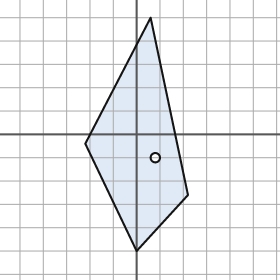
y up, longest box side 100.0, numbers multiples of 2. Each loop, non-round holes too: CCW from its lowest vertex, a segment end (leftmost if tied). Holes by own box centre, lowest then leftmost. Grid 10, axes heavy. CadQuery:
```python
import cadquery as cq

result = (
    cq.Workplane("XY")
    .moveTo(0.0, -50.0)
    .lineTo(22.0, -26.0)
    .lineTo(6.0, 50.0)
    .lineTo(-22.0, -4.0)
    .close()
    .moveTo(8.0, -10.0)
    .circle(2.0)
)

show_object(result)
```